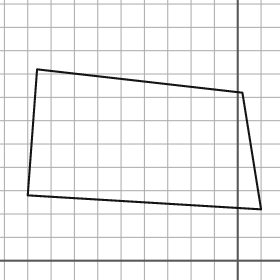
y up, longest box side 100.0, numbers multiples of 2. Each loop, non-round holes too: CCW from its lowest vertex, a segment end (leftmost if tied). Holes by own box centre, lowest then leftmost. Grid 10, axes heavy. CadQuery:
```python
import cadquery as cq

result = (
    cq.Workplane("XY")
    .moveTo(10.0, 22.0)
    .lineTo(2.0, 72.0)
    .lineTo(-86.0, 82.0)
    .lineTo(-90.0, 28.0)
    .close()
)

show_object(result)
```